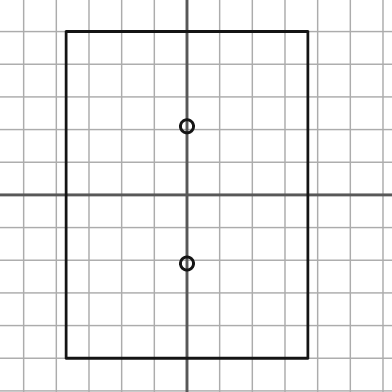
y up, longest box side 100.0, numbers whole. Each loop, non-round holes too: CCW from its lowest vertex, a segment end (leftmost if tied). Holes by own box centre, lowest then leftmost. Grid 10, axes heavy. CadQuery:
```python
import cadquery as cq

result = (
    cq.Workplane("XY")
    .moveTo(-37.0, -50.0)
    .lineTo(37.0, -50.0)
    .lineTo(37.0, 50.0)
    .lineTo(-37.0, 50.0)
    .close()
    .moveTo(0.0, -21.0)
    .circle(2.0)
    .moveTo(0.0, 21.0)
    .circle(2.0)
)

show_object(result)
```